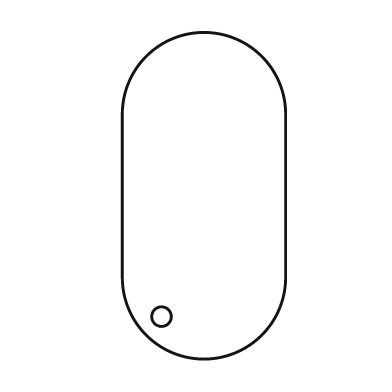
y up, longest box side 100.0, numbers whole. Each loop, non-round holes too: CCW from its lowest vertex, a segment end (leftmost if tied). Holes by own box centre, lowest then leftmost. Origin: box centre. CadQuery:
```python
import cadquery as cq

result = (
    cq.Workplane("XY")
    .moveTo(-25.0, -25.0)
    .threePointArc((0.0, -50.0), (25.0, -25.0))
    .lineTo(25.0, 25.0)
    .threePointArc((0.0, 50.0), (-25.0, 25.0))
    .close()
    .moveTo(-13.0, -37.0)
    .circle(3.0)
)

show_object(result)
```